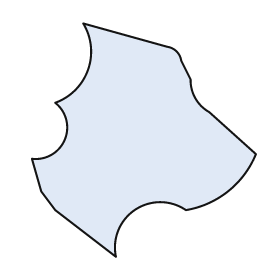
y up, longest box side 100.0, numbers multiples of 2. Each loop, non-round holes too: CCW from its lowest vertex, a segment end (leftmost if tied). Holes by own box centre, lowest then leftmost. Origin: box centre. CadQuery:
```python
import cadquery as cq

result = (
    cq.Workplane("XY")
    .moveTo(-12.0, -50.0)
    .threePointArc((-4.0, -30.0), (18.0, -30.0))
    .threePointArc((36.0, -22.0), (48.0, -6.0))
    .lineTo(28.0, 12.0)
    .threePointArc((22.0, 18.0), (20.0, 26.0))
    .lineTo(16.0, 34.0)
    .threePointArc((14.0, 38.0), (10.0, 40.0))
    .lineTo(-26.0, 50.0)
    .threePointArc((-24.0, 30.0), (-38.0, 16.0))
    .threePointArc((-34.0, 0.0), (-48.0, -8.0))
    .lineTo(-44.0, -22.0)
    .lineTo(-38.0, -30.0)
    .close()
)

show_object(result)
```